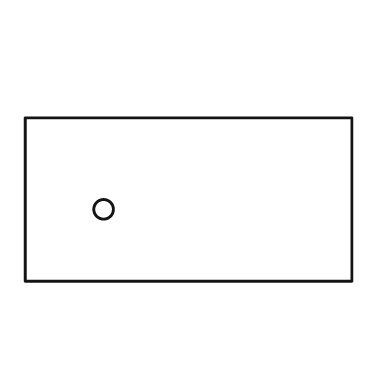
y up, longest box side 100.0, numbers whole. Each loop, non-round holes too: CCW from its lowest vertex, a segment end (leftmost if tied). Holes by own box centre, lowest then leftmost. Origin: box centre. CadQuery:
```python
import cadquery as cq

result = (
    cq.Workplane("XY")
    .moveTo(-50.0, -25.0)
    .lineTo(50.0, -25.0)
    .lineTo(50.0, 25.0)
    .lineTo(-50.0, 25.0)
    .close()
    .moveTo(-26.0, -3.0)
    .circle(3.0)
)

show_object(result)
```